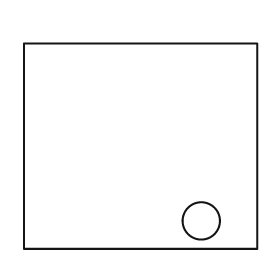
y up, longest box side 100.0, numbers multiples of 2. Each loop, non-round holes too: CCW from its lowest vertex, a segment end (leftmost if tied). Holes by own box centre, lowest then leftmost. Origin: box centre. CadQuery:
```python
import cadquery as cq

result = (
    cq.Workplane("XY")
    .moveTo(-50.0, -44.0)
    .lineTo(50.0, -44.0)
    .lineTo(50.0, 44.0)
    .lineTo(-50.0, 44.0)
    .close()
    .moveTo(26.0, -32.0)
    .circle(8.0)
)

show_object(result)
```